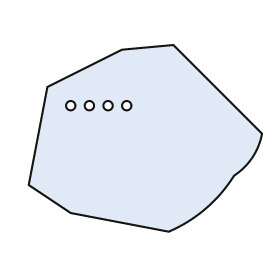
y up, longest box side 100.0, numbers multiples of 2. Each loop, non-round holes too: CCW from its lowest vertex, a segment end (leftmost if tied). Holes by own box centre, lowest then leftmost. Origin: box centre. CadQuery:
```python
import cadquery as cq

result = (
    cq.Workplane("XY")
    .moveTo(10.0, -40.0)
    .threePointArc((26.0, -30.0), (38.0, -16.0))
    .threePointArc((46.0, -8.0), (50.0, 2.0))
    .lineTo(12.0, 40.0)
    .lineTo(-10.0, 38.0)
    .lineTo(-42.0, 22.0)
    .lineTo(-50.0, -20.0)
    .lineTo(-32.0, -32.0)
    .close()
    .moveTo(-32.0, 14.0)
    .circle(2.0)
    .moveTo(-24.0, 14.0)
    .circle(2.0)
    .moveTo(-16.0, 14.0)
    .circle(2.0)
    .moveTo(-8.0, 14.0)
    .circle(2.0)
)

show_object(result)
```